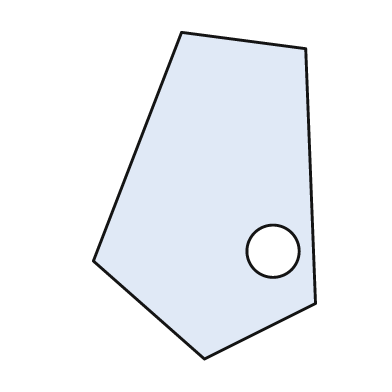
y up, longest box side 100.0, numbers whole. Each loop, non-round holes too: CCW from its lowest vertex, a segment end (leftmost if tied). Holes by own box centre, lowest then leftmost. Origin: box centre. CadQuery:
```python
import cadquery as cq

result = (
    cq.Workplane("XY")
    .moveTo(0.0, -50.0)
    .lineTo(34.0, -33.0)
    .lineTo(31.0, 45.0)
    .lineTo(-7.0, 50.0)
    .lineTo(-34.0, -20.0)
    .close()
    .moveTo(21.0, -17.0)
    .circle(8.0)
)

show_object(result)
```